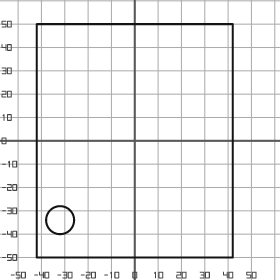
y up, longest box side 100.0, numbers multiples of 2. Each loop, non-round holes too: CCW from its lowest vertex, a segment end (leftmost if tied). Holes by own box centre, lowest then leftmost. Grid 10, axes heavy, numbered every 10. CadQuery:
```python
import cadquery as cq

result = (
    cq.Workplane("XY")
    .moveTo(-42.0, -50.0)
    .lineTo(42.0, -50.0)
    .lineTo(42.0, 50.0)
    .lineTo(-42.0, 50.0)
    .close()
    .moveTo(-32.0, -34.0)
    .circle(6.0)
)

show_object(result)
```